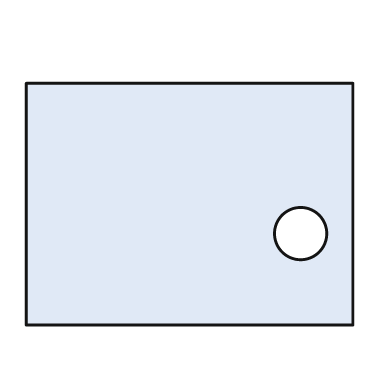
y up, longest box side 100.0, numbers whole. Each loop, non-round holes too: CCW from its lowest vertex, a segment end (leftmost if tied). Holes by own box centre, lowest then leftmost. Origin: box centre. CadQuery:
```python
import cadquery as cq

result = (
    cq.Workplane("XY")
    .moveTo(-50.0, -37.0)
    .lineTo(50.0, -37.0)
    .lineTo(50.0, 37.0)
    .lineTo(-50.0, 37.0)
    .close()
    .moveTo(34.0, -9.0)
    .circle(8.0)
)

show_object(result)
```